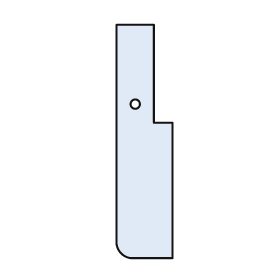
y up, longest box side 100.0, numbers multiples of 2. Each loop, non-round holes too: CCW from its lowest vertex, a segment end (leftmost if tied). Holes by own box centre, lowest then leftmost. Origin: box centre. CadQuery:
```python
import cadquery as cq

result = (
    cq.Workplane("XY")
    .moveTo(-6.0, -50.0)
    .lineTo(12.0, -50.0)
    .lineTo(12.0, 8.0)
    .lineTo(4.0, 8.0)
    .lineTo(4.0, 50.0)
    .lineTo(-12.0, 50.0)
    .lineTo(-12.0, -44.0)
    .threePointArc((-10.0, -48.0), (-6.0, -50.0))
    .close()
    .moveTo(-4.0, 16.0)
    .circle(2.0)
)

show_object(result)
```